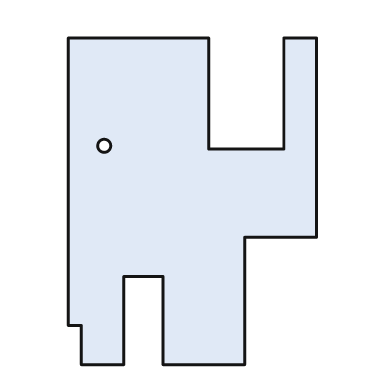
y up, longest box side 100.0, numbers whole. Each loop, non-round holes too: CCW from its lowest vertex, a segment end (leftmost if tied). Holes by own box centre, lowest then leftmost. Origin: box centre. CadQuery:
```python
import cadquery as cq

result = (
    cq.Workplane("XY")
    .moveTo(-34.0, -50.0)
    .lineTo(-21.0, -50.0)
    .lineTo(-21.0, -23.0)
    .lineTo(-9.0, -23.0)
    .lineTo(-9.0, -50.0)
    .lineTo(16.0, -50.0)
    .lineTo(16.0, -11.0)
    .lineTo(38.0, -11.0)
    .lineTo(38.0, 50.0)
    .lineTo(28.0, 50.0)
    .lineTo(28.0, 16.0)
    .lineTo(5.0, 16.0)
    .lineTo(5.0, 50.0)
    .lineTo(-38.0, 50.0)
    .lineTo(-38.0, -38.0)
    .lineTo(-34.0, -38.0)
    .close()
    .moveTo(-27.0, 17.0)
    .circle(2.0)
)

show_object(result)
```